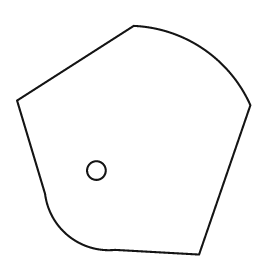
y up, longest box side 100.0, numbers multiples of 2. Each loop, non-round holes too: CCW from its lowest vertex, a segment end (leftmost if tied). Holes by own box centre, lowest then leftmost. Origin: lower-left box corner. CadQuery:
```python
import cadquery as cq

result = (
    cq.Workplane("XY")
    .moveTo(78.0, 0.0)
    .lineTo(100.0, 64.0)
    .threePointArc((80.0, 88.0), (50.0, 98.0))
    .lineTo(0.0, 66.0)
    .lineTo(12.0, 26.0)
    .threePointArc((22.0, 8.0), (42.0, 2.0))
    .close()
    .moveTo(34.0, 36.0)
    .circle(4.0)
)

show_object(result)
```